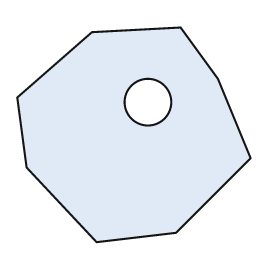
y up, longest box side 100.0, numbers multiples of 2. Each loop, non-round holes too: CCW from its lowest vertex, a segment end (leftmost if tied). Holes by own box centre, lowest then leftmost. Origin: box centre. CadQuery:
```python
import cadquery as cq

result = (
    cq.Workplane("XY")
    .moveTo(-16.0, -46.0)
    .lineTo(18.0, -42.0)
    .lineTo(50.0, -10.0)
    .lineTo(36.0, 24.0)
    .lineTo(20.0, 46.0)
    .lineTo(-18.0, 44.0)
    .lineTo(-50.0, 16.0)
    .lineTo(-46.0, -14.0)
    .close()
    .moveTo(6.0, 14.0)
    .circle(10.0)
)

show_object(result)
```